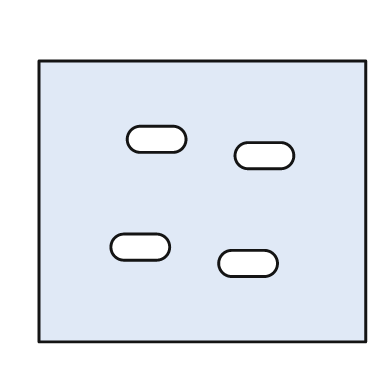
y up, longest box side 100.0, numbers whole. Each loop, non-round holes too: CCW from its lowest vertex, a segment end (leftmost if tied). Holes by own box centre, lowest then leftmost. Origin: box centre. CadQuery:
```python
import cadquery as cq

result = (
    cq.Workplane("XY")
    .moveTo(-50.0, -43.0)
    .lineTo(50.0, -43.0)
    .lineTo(50.0, 43.0)
    .lineTo(-50.0, 43.0)
    .close()
    .moveTo(9.0, -23.0)
    .lineTo(19.0, -23.0)
    .threePointArc((23.0, -19.0), (19.0, -15.0))
    .lineTo(9.0, -15.0)
    .threePointArc((5.0, -19.0), (9.0, -23.0))
    .close()
    .moveTo(-24.0, -18.0)
    .lineTo(-14.0, -18.0)
    .threePointArc((-10.0, -14.0), (-14.0, -10.0))
    .lineTo(-24.0, -10.0)
    .threePointArc((-28.0, -14.0), (-24.0, -18.0))
    .close()
    .moveTo(14.0, 10.0)
    .lineTo(24.0, 10.0)
    .threePointArc((28.0, 14.0), (24.0, 18.0))
    .lineTo(14.0, 18.0)
    .threePointArc((10.0, 14.0), (14.0, 10.0))
    .close()
    .moveTo(-19.0, 15.0)
    .lineTo(-9.0, 15.0)
    .threePointArc((-5.0, 19.0), (-9.0, 23.0))
    .lineTo(-19.0, 23.0)
    .threePointArc((-23.0, 19.0), (-19.0, 15.0))
    .close()
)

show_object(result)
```